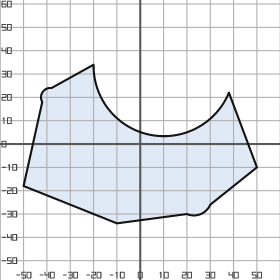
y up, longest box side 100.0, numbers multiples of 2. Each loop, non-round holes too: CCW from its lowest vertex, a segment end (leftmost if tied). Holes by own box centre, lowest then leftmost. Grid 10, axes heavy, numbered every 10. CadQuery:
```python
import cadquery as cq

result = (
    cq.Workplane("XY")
    .moveTo(-10.0, -34.0)
    .lineTo(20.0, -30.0)
    .threePointArc((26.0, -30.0), (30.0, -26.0))
    .lineTo(50.0, -10.0)
    .lineTo(38.0, 22.0)
    .threePointArc((4.0, 4.0), (-20.0, 34.0))
    .lineTo(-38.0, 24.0)
    .threePointArc((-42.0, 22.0), (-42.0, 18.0))
    .lineTo(-50.0, -18.0)
    .close()
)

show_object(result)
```